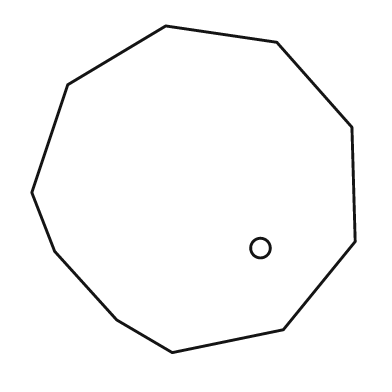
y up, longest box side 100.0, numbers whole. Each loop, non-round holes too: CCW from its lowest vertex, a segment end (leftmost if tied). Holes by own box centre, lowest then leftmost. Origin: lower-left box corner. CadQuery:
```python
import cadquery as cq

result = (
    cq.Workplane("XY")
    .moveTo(43.0, 0.0)
    .lineTo(77.0, 7.0)
    .lineTo(99.0, 34.0)
    .lineTo(98.0, 69.0)
    .lineTo(75.0, 95.0)
    .lineTo(41.0, 100.0)
    .lineTo(11.0, 82.0)
    .lineTo(0.0, 49.0)
    .lineTo(7.0, 31.0)
    .lineTo(26.0, 10.0)
    .close()
    .moveTo(70.0, 32.0)
    .circle(3.0)
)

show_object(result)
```